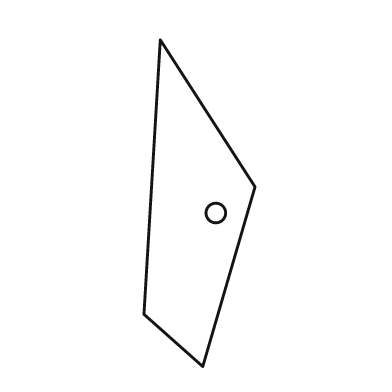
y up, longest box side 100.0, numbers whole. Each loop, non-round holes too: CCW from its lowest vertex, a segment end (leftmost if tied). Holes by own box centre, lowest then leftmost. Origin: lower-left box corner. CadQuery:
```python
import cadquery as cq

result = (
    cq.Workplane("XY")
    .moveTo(18.0, 0.0)
    .lineTo(34.0, 55.0)
    .lineTo(5.0, 100.0)
    .lineTo(0.0, 16.0)
    .close()
    .moveTo(22.0, 47.0)
    .circle(3.0)
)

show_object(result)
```